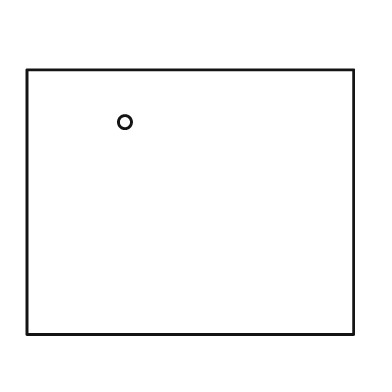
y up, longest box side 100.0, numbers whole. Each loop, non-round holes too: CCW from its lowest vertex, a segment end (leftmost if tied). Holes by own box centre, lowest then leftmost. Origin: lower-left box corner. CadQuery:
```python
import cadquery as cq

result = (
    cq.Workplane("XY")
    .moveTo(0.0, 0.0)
    .lineTo(100.0, 0.0)
    .lineTo(100.0, 81.0)
    .lineTo(0.0, 81.0)
    .close()
    .moveTo(30.0, 65.0)
    .circle(2.0)
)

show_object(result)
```